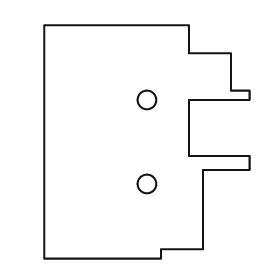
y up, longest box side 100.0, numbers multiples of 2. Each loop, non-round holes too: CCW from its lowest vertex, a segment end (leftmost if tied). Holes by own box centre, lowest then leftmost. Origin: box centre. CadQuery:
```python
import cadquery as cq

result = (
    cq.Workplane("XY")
    .moveTo(-44.0, -50.0)
    .lineTo(6.0, -50.0)
    .lineTo(6.0, -46.0)
    .lineTo(24.0, -46.0)
    .lineTo(24.0, -12.0)
    .lineTo(44.0, -12.0)
    .lineTo(44.0, -6.0)
    .lineTo(18.0, -6.0)
    .lineTo(18.0, 18.0)
    .lineTo(44.0, 18.0)
    .lineTo(44.0, 22.0)
    .lineTo(36.0, 22.0)
    .lineTo(36.0, 38.0)
    .lineTo(18.0, 38.0)
    .lineTo(18.0, 50.0)
    .lineTo(-44.0, 50.0)
    .close()
    .moveTo(0.0, -18.0)
    .circle(4.0)
    .moveTo(0.0, 18.0)
    .circle(4.0)
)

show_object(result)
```